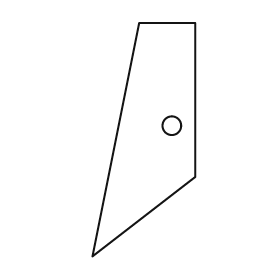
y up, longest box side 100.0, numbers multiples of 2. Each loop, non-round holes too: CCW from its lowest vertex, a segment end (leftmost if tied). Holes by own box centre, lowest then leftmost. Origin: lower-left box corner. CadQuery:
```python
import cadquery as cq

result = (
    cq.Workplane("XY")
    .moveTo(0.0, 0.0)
    .lineTo(44.0, 34.0)
    .lineTo(44.0, 100.0)
    .lineTo(20.0, 100.0)
    .close()
    .moveTo(34.0, 56.0)
    .circle(4.0)
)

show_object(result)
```